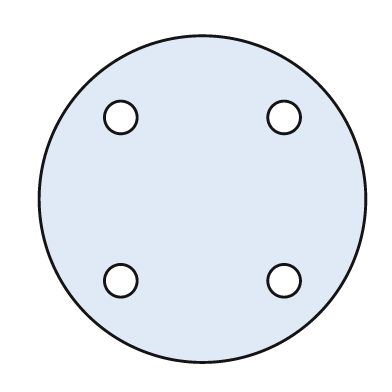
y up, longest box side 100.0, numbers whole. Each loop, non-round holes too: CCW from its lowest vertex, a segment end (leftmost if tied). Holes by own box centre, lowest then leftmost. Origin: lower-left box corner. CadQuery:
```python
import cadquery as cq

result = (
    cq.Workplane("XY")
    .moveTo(50.0, 50.0)
    .circle(50.0)
    .moveTo(25.0, 25.0)
    .circle(5.0)
    .moveTo(75.0, 25.0)
    .circle(5.0)
    .moveTo(25.0, 75.0)
    .circle(5.0)
    .moveTo(75.0, 75.0)
    .circle(5.0)
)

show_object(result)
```